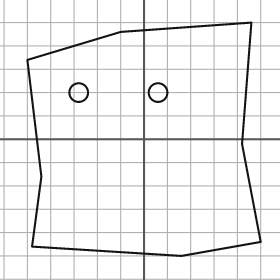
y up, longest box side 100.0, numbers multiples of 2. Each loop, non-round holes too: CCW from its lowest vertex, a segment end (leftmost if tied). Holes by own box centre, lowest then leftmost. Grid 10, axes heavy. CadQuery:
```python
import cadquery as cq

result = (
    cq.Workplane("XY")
    .moveTo(16.0, -50.0)
    .lineTo(50.0, -44.0)
    .lineTo(42.0, -2.0)
    .lineTo(46.0, 50.0)
    .lineTo(-10.0, 46.0)
    .lineTo(-50.0, 34.0)
    .lineTo(-44.0, -16.0)
    .lineTo(-48.0, -46.0)
    .close()
    .moveTo(-28.0, 20.0)
    .circle(4.0)
    .moveTo(6.0, 20.0)
    .circle(4.0)
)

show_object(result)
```